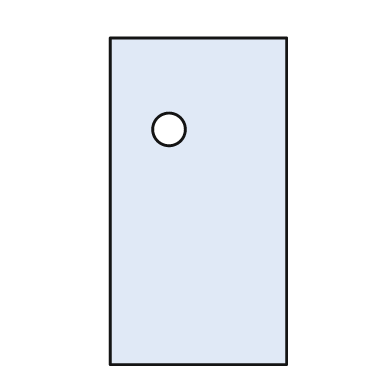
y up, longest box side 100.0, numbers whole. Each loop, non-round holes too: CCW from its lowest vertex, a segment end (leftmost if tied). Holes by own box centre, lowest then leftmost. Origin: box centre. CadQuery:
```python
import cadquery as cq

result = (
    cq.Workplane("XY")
    .moveTo(-27.0, -50.0)
    .lineTo(27.0, -50.0)
    .lineTo(27.0, 50.0)
    .lineTo(-27.0, 50.0)
    .close()
    .moveTo(-9.0, 22.0)
    .circle(5.0)
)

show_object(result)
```